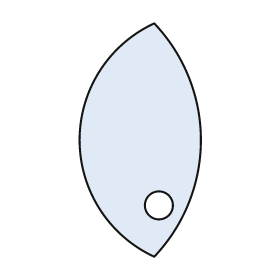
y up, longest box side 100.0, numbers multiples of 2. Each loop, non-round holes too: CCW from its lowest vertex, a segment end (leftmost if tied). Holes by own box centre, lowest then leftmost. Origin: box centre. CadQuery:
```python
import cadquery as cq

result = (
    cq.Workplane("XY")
    .moveTo(6.0, -50.0)
    .threePointArc((26.0, 0.0), (6.0, 50.0))
    .threePointArc((-26.0, 0.0), (6.0, -50.0))
    .close()
    .moveTo(8.0, -28.0)
    .circle(6.0)
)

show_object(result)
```